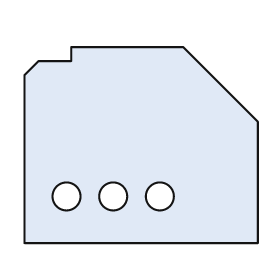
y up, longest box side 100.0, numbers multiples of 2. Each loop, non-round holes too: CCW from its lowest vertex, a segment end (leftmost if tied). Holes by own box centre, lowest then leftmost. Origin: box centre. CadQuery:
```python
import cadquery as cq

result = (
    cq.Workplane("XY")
    .moveTo(-50.0, -42.0)
    .lineTo(50.0, -42.0)
    .lineTo(50.0, 10.0)
    .lineTo(18.0, 42.0)
    .lineTo(-30.0, 42.0)
    .lineTo(-30.0, 36.0)
    .lineTo(-44.0, 36.0)
    .lineTo(-50.0, 30.0)
    .close()
    .moveTo(-32.0, -22.0)
    .circle(6.0)
    .moveTo(-12.0, -22.0)
    .circle(6.0)
    .moveTo(8.0, -22.0)
    .circle(6.0)
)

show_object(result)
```